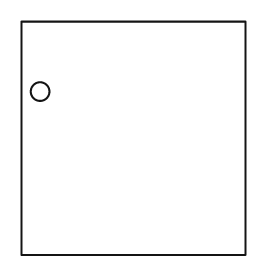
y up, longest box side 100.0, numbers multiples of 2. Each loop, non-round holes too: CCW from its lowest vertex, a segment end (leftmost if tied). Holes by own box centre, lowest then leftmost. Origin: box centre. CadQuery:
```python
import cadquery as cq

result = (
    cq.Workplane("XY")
    .moveTo(-48.0, -50.0)
    .lineTo(48.0, -50.0)
    .lineTo(48.0, 50.0)
    .lineTo(-48.0, 50.0)
    .close()
    .moveTo(-40.0, 20.0)
    .circle(4.0)
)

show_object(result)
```